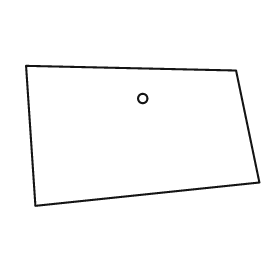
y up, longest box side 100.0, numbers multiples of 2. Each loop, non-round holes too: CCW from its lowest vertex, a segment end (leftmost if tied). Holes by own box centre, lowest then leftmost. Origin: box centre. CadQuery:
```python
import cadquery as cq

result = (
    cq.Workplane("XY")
    .moveTo(-46.0, -30.0)
    .lineTo(50.0, -20.0)
    .lineTo(40.0, 28.0)
    .lineTo(-50.0, 30.0)
    .close()
    .moveTo(0.0, 16.0)
    .circle(2.0)
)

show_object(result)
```